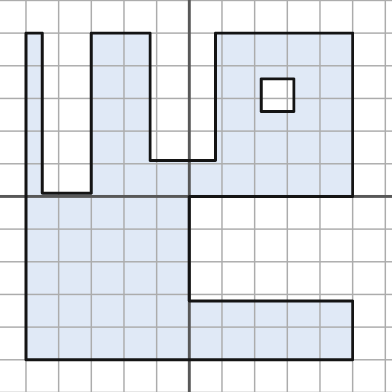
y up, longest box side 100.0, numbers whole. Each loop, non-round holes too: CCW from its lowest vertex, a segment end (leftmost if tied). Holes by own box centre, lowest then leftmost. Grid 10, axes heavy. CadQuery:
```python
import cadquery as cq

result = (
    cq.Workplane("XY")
    .moveTo(-50.0, -50.0)
    .lineTo(50.0, -50.0)
    .lineTo(50.0, -32.0)
    .lineTo(0.0, -32.0)
    .lineTo(0.0, 0.0)
    .lineTo(50.0, 0.0)
    .lineTo(50.0, 50.0)
    .lineTo(8.0, 50.0)
    .lineTo(8.0, 11.0)
    .lineTo(-12.0, 11.0)
    .lineTo(-12.0, 50.0)
    .lineTo(-30.0, 50.0)
    .lineTo(-30.0, 1.0)
    .lineTo(-45.0, 1.0)
    .lineTo(-45.0, 50.0)
    .lineTo(-50.0, 50.0)
    .close()
    .moveTo(22.0, 26.0)
    .lineTo(32.0, 26.0)
    .lineTo(32.0, 36.0)
    .lineTo(22.0, 36.0)
    .close()
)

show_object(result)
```